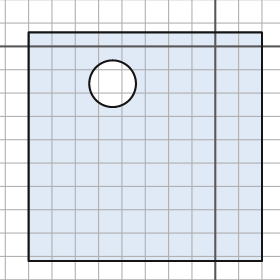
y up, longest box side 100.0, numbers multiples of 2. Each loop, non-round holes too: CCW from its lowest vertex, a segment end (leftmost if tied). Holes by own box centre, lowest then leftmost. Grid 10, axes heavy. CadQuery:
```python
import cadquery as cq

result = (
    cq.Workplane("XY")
    .moveTo(-80.0, -92.0)
    .lineTo(20.0, -92.0)
    .lineTo(20.0, 6.0)
    .lineTo(-80.0, 6.0)
    .close()
    .moveTo(-44.0, -16.0)
    .circle(10.0)
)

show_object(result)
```